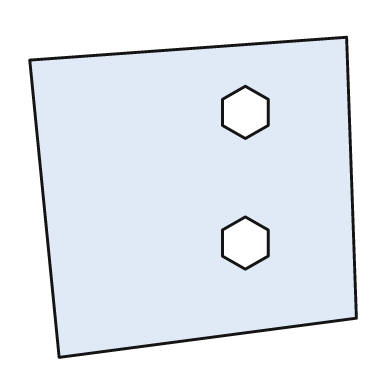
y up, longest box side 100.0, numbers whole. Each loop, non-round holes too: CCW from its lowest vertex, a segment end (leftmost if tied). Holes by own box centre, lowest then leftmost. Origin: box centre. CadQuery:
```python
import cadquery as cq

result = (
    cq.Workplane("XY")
    .moveTo(-41.0, -49.0)
    .lineTo(50.0, -37.0)
    .lineTo(47.0, 49.0)
    .lineTo(-50.0, 42.0)
    .close()
    .moveTo(16.0, -22.0)
    .lineTo(23.0, -18.0)
    .lineTo(23.0, -10.0)
    .lineTo(16.0, -6.0)
    .lineTo(9.0, -10.0)
    .lineTo(9.0, -18.0)
    .close()
    .moveTo(16.0, 18.0)
    .lineTo(23.0, 22.0)
    .lineTo(23.0, 30.0)
    .lineTo(16.0, 34.0)
    .lineTo(9.0, 30.0)
    .lineTo(9.0, 22.0)
    .close()
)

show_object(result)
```